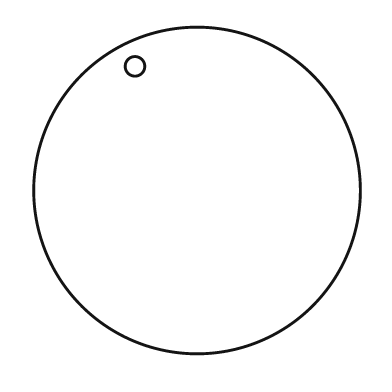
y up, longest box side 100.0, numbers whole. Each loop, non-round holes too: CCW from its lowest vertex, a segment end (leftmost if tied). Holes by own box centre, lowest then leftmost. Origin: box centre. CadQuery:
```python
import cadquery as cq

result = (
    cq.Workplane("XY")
    .moveTo(0.0, 0.0)
    .circle(50.0)
    .moveTo(-19.0, 38.0)
    .circle(3.0)
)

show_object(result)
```